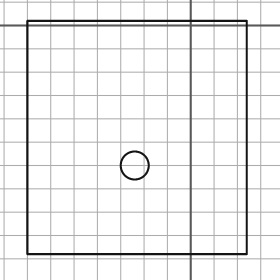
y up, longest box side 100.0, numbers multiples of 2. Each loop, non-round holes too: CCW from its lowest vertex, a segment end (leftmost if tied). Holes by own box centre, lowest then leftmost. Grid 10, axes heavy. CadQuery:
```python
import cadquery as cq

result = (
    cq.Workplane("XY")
    .moveTo(-70.0, -98.0)
    .lineTo(24.0, -98.0)
    .lineTo(24.0, 2.0)
    .lineTo(-70.0, 2.0)
    .close()
    .moveTo(-24.0, -60.0)
    .circle(6.0)
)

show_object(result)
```